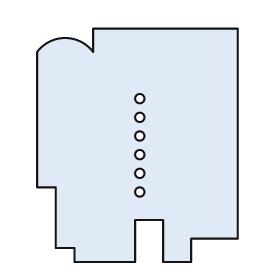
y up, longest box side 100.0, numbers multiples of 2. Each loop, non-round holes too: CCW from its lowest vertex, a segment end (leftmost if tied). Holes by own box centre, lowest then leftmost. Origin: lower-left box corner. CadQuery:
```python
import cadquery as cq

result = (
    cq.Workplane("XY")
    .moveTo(16.0, 0.0)
    .lineTo(42.0, 0.0)
    .lineTo(42.0, 18.0)
    .lineTo(54.0, 18.0)
    .lineTo(54.0, 0.0)
    .lineTo(66.0, 0.0)
    .lineTo(66.0, 10.0)
    .lineTo(86.0, 10.0)
    .lineTo(86.0, 100.0)
    .lineTo(24.0, 100.0)
    .lineTo(24.0, 90.0)
    .threePointArc((12.0, 96.0), (0.0, 90.0))
    .lineTo(0.0, 32.0)
    .lineTo(8.0, 32.0)
    .lineTo(8.0, 6.0)
    .lineTo(16.0, 6.0)
    .close()
    .moveTo(44.0, 30.0)
    .circle(2.0)
    .moveTo(44.0, 38.0)
    .circle(2.0)
    .moveTo(44.0, 46.0)
    .circle(2.0)
    .moveTo(44.0, 54.0)
    .circle(2.0)
    .moveTo(44.0, 62.0)
    .circle(2.0)
    .moveTo(44.0, 70.0)
    .circle(2.0)
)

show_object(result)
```